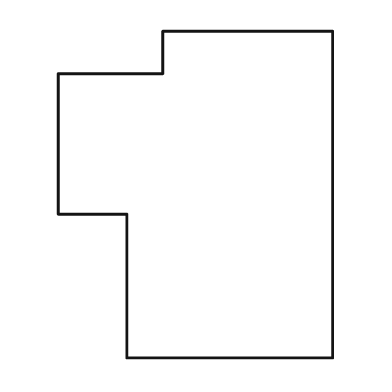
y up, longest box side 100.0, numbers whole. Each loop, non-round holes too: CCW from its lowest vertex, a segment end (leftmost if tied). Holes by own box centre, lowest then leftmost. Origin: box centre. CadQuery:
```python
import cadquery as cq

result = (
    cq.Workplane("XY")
    .moveTo(-21.0, -50.0)
    .lineTo(42.0, -50.0)
    .lineTo(42.0, 50.0)
    .lineTo(-10.0, 50.0)
    .lineTo(-10.0, 37.0)
    .lineTo(-42.0, 37.0)
    .lineTo(-42.0, -6.0)
    .lineTo(-21.0, -6.0)
    .close()
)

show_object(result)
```